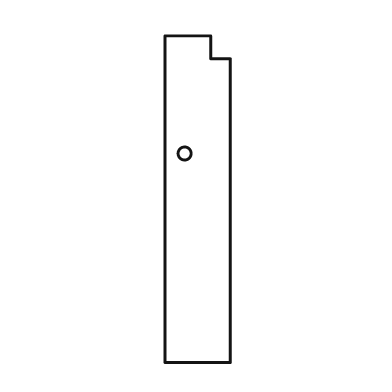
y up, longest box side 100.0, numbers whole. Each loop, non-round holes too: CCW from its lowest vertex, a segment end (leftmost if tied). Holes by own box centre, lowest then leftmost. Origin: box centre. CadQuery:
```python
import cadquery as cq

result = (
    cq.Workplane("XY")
    .moveTo(-10.0, -50.0)
    .lineTo(10.0, -50.0)
    .lineTo(10.0, 43.0)
    .lineTo(4.0, 43.0)
    .lineTo(4.0, 50.0)
    .lineTo(-10.0, 50.0)
    .close()
    .moveTo(-4.0, 14.0)
    .circle(2.0)
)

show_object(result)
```